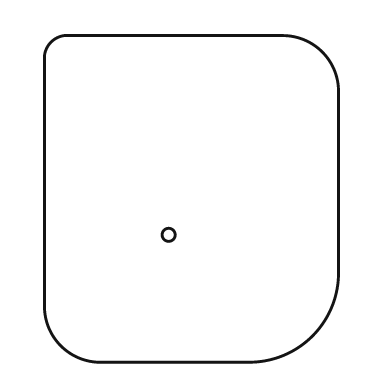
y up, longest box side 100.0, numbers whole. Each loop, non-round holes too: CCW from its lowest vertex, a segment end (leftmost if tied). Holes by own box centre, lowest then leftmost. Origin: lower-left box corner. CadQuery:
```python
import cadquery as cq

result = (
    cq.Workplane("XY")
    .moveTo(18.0, 0.0)
    .lineTo(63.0, 0.0)
    .threePointArc((82.0, 8.0), (90.0, 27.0))
    .lineTo(90.0, 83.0)
    .threePointArc((85.0, 95.0), (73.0, 100.0))
    .lineTo(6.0, 100.0)
    .threePointArc((2.0, 98.0), (0.0, 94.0))
    .lineTo(0.0, 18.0)
    .threePointArc((5.0, 5.0), (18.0, 0.0))
    .close()
    .moveTo(38.0, 39.0)
    .circle(2.0)
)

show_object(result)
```